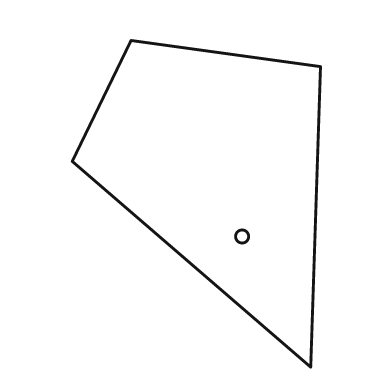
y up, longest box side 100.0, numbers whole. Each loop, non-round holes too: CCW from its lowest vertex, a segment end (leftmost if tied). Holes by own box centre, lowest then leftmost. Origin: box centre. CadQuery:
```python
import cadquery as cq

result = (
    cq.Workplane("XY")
    .moveTo(35.0, -50.0)
    .lineTo(38.0, 42.0)
    .lineTo(-20.0, 50.0)
    .lineTo(-38.0, 13.0)
    .close()
    .moveTo(14.0, -10.0)
    .circle(2.0)
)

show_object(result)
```